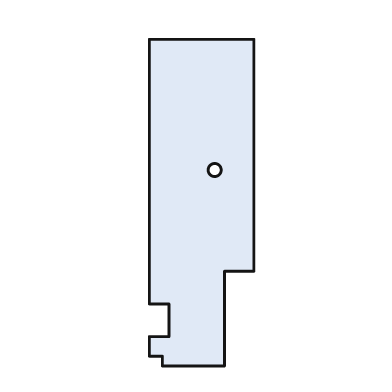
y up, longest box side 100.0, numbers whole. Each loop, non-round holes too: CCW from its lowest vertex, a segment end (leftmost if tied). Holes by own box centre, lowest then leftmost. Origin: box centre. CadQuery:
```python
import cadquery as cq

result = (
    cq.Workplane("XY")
    .moveTo(-12.0, -50.0)
    .lineTo(7.0, -50.0)
    .lineTo(7.0, -21.0)
    .lineTo(16.0, -21.0)
    .lineTo(16.0, 50.0)
    .lineTo(-16.0, 50.0)
    .lineTo(-16.0, -31.0)
    .lineTo(-10.0, -31.0)
    .lineTo(-10.0, -41.0)
    .lineTo(-16.0, -41.0)
    .lineTo(-16.0, -47.0)
    .lineTo(-12.0, -47.0)
    .close()
    .moveTo(4.0, 10.0)
    .circle(2.0)
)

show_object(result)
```